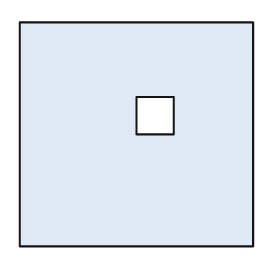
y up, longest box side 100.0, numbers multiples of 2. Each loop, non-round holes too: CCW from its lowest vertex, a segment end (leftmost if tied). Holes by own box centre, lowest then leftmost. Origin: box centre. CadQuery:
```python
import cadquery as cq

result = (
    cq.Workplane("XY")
    .moveTo(-50.0, -48.0)
    .lineTo(50.0, -48.0)
    .lineTo(50.0, 48.0)
    .lineTo(-50.0, 48.0)
    .close()
    .moveTo(0.0, 0.0)
    .lineTo(16.0, 0.0)
    .lineTo(16.0, 16.0)
    .lineTo(0.0, 16.0)
    .close()
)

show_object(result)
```